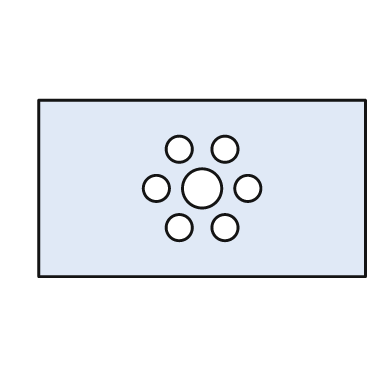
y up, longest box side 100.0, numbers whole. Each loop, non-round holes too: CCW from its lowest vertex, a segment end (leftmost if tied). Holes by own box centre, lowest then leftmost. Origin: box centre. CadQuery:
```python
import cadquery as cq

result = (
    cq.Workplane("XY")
    .moveTo(-50.0, -27.0)
    .lineTo(50.0, -27.0)
    .lineTo(50.0, 27.0)
    .lineTo(-50.0, 27.0)
    .close()
    .moveTo(-7.0, -12.0)
    .circle(4.0)
    .moveTo(7.0, -12.0)
    .circle(4.0)
    .moveTo(-14.0, 0.0)
    .circle(4.0)
    .moveTo(0.0, 0.0)
    .circle(6.0)
    .moveTo(14.0, 0.0)
    .circle(4.0)
    .moveTo(-7.0, 12.0)
    .circle(4.0)
    .moveTo(7.0, 12.0)
    .circle(4.0)
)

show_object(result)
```